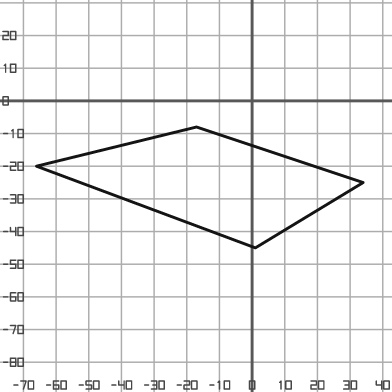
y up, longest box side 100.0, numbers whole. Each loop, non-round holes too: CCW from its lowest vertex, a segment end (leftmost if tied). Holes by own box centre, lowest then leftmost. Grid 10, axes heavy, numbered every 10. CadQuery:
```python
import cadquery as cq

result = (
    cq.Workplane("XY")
    .moveTo(1.0, -45.0)
    .lineTo(34.0, -25.0)
    .lineTo(-17.0, -8.0)
    .lineTo(-66.0, -20.0)
    .close()
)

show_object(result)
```